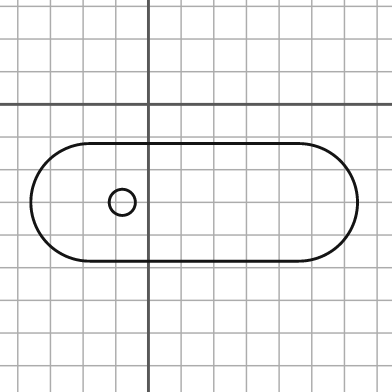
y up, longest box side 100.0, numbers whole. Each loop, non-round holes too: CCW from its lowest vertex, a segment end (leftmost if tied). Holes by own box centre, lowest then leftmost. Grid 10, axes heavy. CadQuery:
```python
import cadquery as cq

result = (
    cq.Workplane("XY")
    .moveTo(-18.0, -48.0)
    .lineTo(46.0, -48.0)
    .threePointArc((64.0, -30.0), (46.0, -12.0))
    .lineTo(-18.0, -12.0)
    .threePointArc((-36.0, -30.0), (-18.0, -48.0))
    .close()
    .moveTo(-8.0, -30.0)
    .circle(4.0)
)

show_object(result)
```